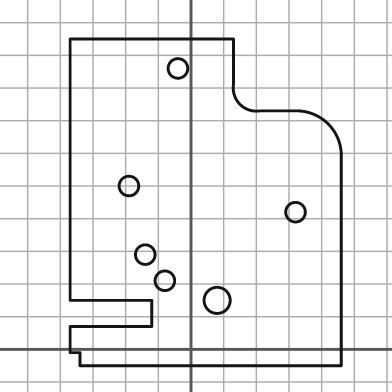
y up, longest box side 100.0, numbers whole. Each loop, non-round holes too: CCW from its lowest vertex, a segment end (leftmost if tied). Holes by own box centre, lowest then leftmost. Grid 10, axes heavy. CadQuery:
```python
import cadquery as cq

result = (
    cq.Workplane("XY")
    .moveTo(-34.0, -5.0)
    .lineTo(46.0, -5.0)
    .lineTo(46.0, 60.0)
    .threePointArc((42.0, 69.0), (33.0, 73.0))
    .lineTo(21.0, 73.0)
    .threePointArc((15.0, 75.0), (13.0, 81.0))
    .lineTo(13.0, 95.0)
    .lineTo(-37.0, 95.0)
    .lineTo(-37.0, 15.0)
    .lineTo(-12.0, 15.0)
    .lineTo(-12.0, 7.0)
    .lineTo(-37.0, 7.0)
    .lineTo(-37.0, -1.0)
    .lineTo(-34.0, -1.0)
    .close()
    .moveTo(8.0, 15.0)
    .circle(4.0)
    .moveTo(-8.0, 21.0)
    .circle(3.0)
    .moveTo(-14.0, 29.0)
    .circle(3.0)
    .moveTo(32.0, 42.0)
    .circle(3.0)
    .moveTo(-19.0, 50.0)
    .circle(3.0)
    .moveTo(-4.0, 86.0)
    .circle(3.0)
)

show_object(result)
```